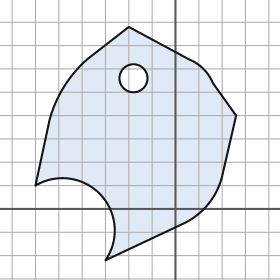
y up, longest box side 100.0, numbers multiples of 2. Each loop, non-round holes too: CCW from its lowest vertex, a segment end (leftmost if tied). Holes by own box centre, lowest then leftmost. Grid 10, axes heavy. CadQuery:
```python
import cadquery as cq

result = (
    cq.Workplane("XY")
    .moveTo(-30.0, -22.0)
    .lineTo(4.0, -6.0)
    .threePointArc((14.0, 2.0), (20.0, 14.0))
    .lineTo(26.0, 40.0)
    .lineTo(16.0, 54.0)
    .threePointArc((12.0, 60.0), (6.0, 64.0))
    .lineTo(-20.0, 78.0)
    .lineTo(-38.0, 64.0)
    .threePointArc((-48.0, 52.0), (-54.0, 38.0))
    .lineTo(-60.0, 10.0)
    .threePointArc((-32.0, 6.0), (-30.0, -22.0))
    .close()
    .moveTo(-18.0, 56.0)
    .circle(6.0)
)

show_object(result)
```